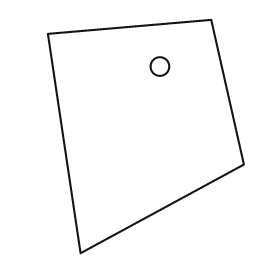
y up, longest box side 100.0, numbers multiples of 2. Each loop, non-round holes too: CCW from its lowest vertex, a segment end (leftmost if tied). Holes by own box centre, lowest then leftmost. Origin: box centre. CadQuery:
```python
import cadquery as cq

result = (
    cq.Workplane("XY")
    .moveTo(-28.0, -50.0)
    .lineTo(42.0, -12.0)
    .lineTo(28.0, 50.0)
    .lineTo(-42.0, 44.0)
    .close()
    .moveTo(6.0, 30.0)
    .circle(4.0)
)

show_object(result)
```